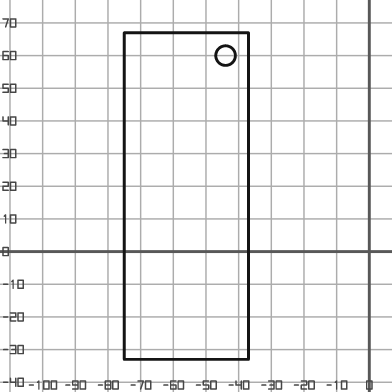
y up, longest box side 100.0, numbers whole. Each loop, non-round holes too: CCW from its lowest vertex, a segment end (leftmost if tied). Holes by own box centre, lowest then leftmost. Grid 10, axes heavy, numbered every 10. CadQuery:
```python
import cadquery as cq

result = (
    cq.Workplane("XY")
    .moveTo(-75.0, -33.0)
    .lineTo(-37.0, -33.0)
    .lineTo(-37.0, 67.0)
    .lineTo(-75.0, 67.0)
    .close()
    .moveTo(-44.0, 60.0)
    .circle(3.0)
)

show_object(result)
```